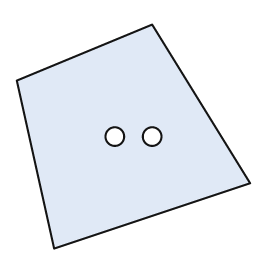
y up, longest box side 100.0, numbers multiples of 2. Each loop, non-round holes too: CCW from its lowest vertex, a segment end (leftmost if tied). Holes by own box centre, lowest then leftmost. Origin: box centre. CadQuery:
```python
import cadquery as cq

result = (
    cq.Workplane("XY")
    .moveTo(-34.0, -48.0)
    .lineTo(50.0, -20.0)
    .lineTo(8.0, 48.0)
    .lineTo(-50.0, 24.0)
    .close()
    .moveTo(-8.0, 0.0)
    .circle(4.0)
    .moveTo(8.0, 0.0)
    .circle(4.0)
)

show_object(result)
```